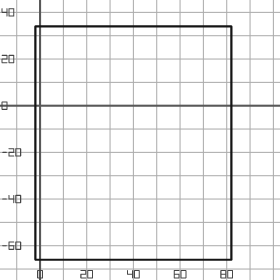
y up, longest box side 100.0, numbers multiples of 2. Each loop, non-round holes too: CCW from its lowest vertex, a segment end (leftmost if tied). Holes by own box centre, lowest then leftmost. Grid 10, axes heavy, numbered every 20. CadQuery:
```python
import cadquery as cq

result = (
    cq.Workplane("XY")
    .moveTo(-2.0, -66.0)
    .lineTo(82.0, -66.0)
    .lineTo(82.0, 34.0)
    .lineTo(-2.0, 34.0)
    .close()
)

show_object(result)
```